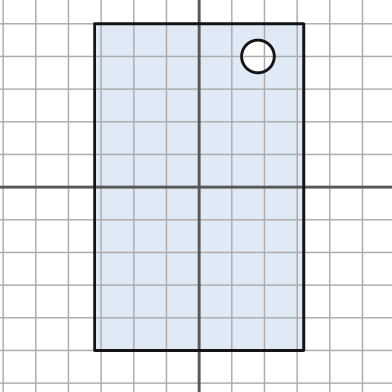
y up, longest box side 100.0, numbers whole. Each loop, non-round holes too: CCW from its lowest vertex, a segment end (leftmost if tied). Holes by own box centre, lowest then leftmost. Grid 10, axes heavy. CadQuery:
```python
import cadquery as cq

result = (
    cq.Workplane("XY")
    .moveTo(-32.0, -50.0)
    .lineTo(32.0, -50.0)
    .lineTo(32.0, 50.0)
    .lineTo(-32.0, 50.0)
    .close()
    .moveTo(18.0, 40.0)
    .circle(5.0)
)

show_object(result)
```